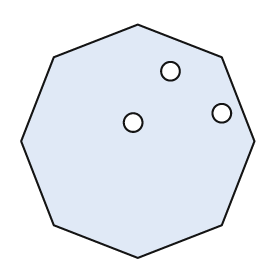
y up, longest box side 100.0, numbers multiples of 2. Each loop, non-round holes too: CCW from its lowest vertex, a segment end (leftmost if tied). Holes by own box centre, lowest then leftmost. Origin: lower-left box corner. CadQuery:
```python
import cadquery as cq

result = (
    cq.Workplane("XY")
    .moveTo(50.0, 0.0)
    .lineTo(86.0, 14.0)
    .lineTo(100.0, 50.0)
    .lineTo(86.0, 86.0)
    .lineTo(50.0, 100.0)
    .lineTo(14.0, 86.0)
    .lineTo(0.0, 50.0)
    .lineTo(14.0, 14.0)
    .close()
    .moveTo(48.0, 58.0)
    .circle(4.0)
    .moveTo(86.0, 62.0)
    .circle(4.0)
    .moveTo(64.0, 80.0)
    .circle(4.0)
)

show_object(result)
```